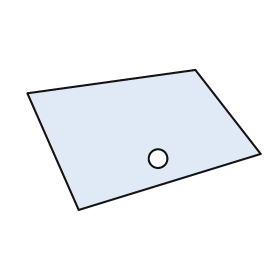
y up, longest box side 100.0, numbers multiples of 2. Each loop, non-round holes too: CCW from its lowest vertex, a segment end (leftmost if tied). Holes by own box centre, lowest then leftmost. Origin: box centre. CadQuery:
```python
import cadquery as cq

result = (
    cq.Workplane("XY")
    .moveTo(-28.0, -30.0)
    .lineTo(50.0, -6.0)
    .lineTo(22.0, 30.0)
    .lineTo(-50.0, 20.0)
    .close()
    .moveTo(6.0, -8.0)
    .circle(4.0)
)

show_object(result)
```